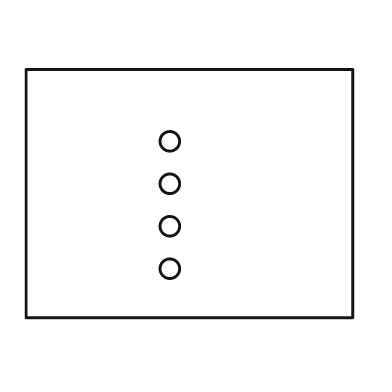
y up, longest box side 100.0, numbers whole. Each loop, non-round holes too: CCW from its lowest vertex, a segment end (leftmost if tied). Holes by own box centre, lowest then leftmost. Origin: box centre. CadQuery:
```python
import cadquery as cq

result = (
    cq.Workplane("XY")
    .moveTo(-50.0, -38.0)
    .lineTo(50.0, -38.0)
    .lineTo(50.0, 38.0)
    .lineTo(-50.0, 38.0)
    .close()
    .moveTo(-6.0, -23.0)
    .circle(3.0)
    .moveTo(-6.0, -10.0)
    .circle(3.0)
    .moveTo(-6.0, 3.0)
    .circle(3.0)
    .moveTo(-6.0, 16.0)
    .circle(3.0)
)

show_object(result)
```